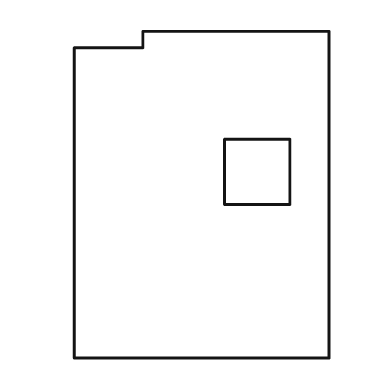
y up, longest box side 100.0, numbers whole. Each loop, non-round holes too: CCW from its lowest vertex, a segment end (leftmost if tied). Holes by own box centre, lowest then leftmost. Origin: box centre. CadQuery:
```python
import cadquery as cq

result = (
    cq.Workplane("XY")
    .moveTo(-39.0, -50.0)
    .lineTo(39.0, -50.0)
    .lineTo(39.0, 50.0)
    .lineTo(-18.0, 50.0)
    .lineTo(-18.0, 45.0)
    .lineTo(-39.0, 45.0)
    .close()
    .moveTo(7.0, -3.0)
    .lineTo(27.0, -3.0)
    .lineTo(27.0, 17.0)
    .lineTo(7.0, 17.0)
    .close()
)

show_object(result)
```